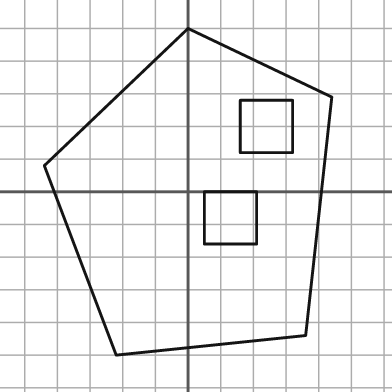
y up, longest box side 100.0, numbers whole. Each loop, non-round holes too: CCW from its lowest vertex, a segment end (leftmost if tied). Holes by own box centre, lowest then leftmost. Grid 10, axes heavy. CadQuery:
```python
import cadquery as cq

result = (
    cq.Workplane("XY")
    .moveTo(-22.0, -50.0)
    .lineTo(36.0, -44.0)
    .lineTo(44.0, 29.0)
    .lineTo(0.0, 50.0)
    .lineTo(-44.0, 8.0)
    .close()
    .moveTo(5.0, -16.0)
    .lineTo(21.0, -16.0)
    .lineTo(21.0, 0.0)
    .lineTo(5.0, 0.0)
    .close()
    .moveTo(16.0, 12.0)
    .lineTo(32.0, 12.0)
    .lineTo(32.0, 28.0)
    .lineTo(16.0, 28.0)
    .close()
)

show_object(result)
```